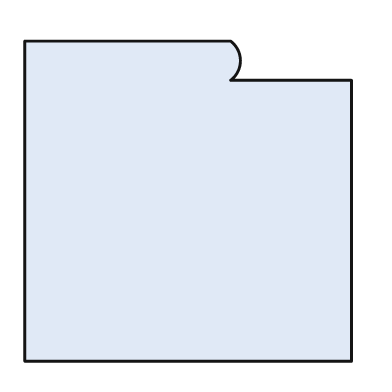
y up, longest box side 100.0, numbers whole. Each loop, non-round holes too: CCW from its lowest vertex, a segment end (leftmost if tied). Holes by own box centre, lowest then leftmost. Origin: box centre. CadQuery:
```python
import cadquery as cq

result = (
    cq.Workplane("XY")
    .moveTo(-50.0, -49.0)
    .lineTo(50.0, -49.0)
    .lineTo(50.0, 37.0)
    .lineTo(13.0, 37.0)
    .threePointArc((16.0, 43.0), (13.0, 49.0))
    .lineTo(-50.0, 49.0)
    .close()
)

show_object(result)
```